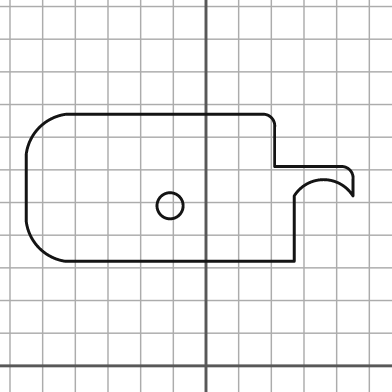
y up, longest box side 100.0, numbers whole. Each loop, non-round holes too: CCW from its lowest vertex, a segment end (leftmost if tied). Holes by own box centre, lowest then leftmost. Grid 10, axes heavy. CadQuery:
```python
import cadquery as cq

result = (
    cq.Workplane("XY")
    .moveTo(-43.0, 32.0)
    .lineTo(27.0, 32.0)
    .lineTo(27.0, 52.0)
    .threePointArc((36.0, 57.0), (45.0, 52.0))
    .lineTo(45.0, 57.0)
    .threePointArc((44.0, 60.0), (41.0, 61.0))
    .lineTo(21.0, 61.0)
    .lineTo(21.0, 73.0)
    .threePointArc((20.0, 76.0), (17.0, 77.0))
    .lineTo(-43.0, 77.0)
    .threePointArc((-51.0, 73.0), (-55.0, 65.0))
    .lineTo(-55.0, 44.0)
    .threePointArc((-51.0, 36.0), (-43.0, 32.0))
    .close()
    .moveTo(-11.0, 49.0)
    .circle(4.0)
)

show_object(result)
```